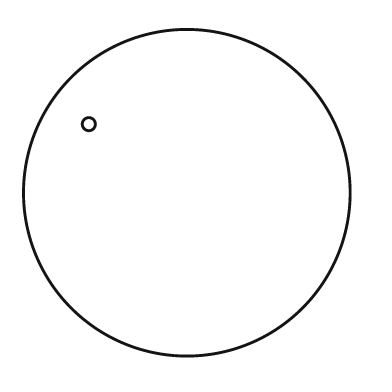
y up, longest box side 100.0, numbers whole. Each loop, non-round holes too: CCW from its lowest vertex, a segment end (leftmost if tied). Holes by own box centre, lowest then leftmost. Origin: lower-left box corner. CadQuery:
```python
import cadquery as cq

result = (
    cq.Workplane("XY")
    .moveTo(50.0, 50.0)
    .circle(50.0)
    .moveTo(20.0, 71.0)
    .circle(2.0)
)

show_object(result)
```